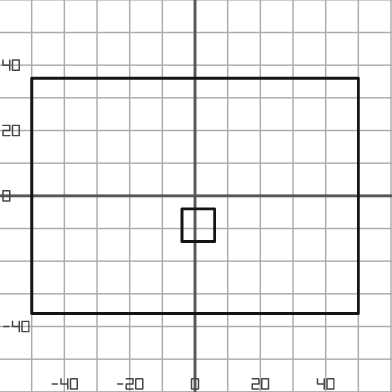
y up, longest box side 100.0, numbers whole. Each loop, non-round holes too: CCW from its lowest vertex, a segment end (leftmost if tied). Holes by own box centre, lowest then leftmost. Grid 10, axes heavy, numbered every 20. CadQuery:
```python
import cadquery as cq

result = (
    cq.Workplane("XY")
    .moveTo(-50.0, -36.0)
    .lineTo(50.0, -36.0)
    .lineTo(50.0, 36.0)
    .lineTo(-50.0, 36.0)
    .close()
    .moveTo(-4.0, -14.0)
    .lineTo(6.0, -14.0)
    .lineTo(6.0, -4.0)
    .lineTo(-4.0, -4.0)
    .close()
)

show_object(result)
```